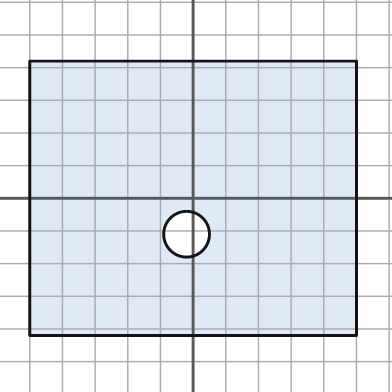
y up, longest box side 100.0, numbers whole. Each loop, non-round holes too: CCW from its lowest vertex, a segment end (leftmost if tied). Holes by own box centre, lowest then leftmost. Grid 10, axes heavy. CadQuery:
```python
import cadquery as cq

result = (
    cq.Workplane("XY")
    .moveTo(-50.0, -42.0)
    .lineTo(50.0, -42.0)
    .lineTo(50.0, 42.0)
    .lineTo(-50.0, 42.0)
    .close()
    .moveTo(-2.0, -11.0)
    .circle(7.0)
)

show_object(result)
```